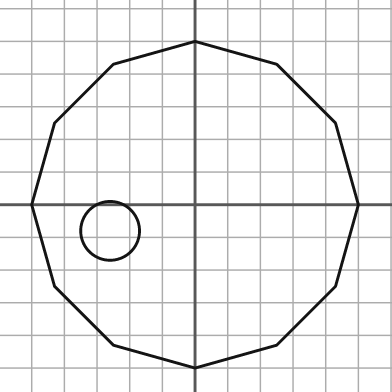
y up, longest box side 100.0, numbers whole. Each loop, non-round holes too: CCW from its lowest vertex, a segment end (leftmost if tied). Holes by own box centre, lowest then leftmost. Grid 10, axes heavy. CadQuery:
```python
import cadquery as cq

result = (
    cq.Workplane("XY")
    .moveTo(0.0, -50.0)
    .lineTo(25.0, -43.0)
    .lineTo(43.0, -25.0)
    .lineTo(50.0, 0.0)
    .lineTo(43.0, 25.0)
    .lineTo(25.0, 43.0)
    .lineTo(0.0, 50.0)
    .lineTo(-25.0, 43.0)
    .lineTo(-43.0, 25.0)
    .lineTo(-50.0, 0.0)
    .lineTo(-43.0, -25.0)
    .lineTo(-25.0, -43.0)
    .close()
    .moveTo(-26.0, -8.0)
    .circle(9.0)
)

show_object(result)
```